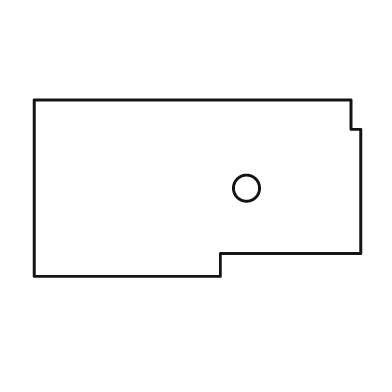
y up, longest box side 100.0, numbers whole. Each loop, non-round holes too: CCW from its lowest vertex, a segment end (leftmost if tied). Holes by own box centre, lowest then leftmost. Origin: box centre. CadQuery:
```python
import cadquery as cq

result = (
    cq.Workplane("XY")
    .moveTo(-50.0, -27.0)
    .lineTo(7.0, -27.0)
    .lineTo(7.0, -20.0)
    .lineTo(50.0, -20.0)
    .lineTo(50.0, 18.0)
    .lineTo(47.0, 18.0)
    .lineTo(47.0, 27.0)
    .lineTo(-50.0, 27.0)
    .close()
    .moveTo(15.0, 0.0)
    .circle(4.0)
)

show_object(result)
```